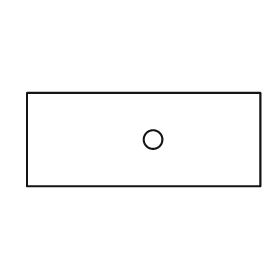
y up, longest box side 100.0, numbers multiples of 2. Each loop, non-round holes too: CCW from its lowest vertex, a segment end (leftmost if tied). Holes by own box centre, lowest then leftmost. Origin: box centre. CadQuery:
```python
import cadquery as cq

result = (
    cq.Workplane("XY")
    .moveTo(-50.0, -20.0)
    .lineTo(50.0, -20.0)
    .lineTo(50.0, 20.0)
    .lineTo(-50.0, 20.0)
    .close()
    .moveTo(4.0, 0.0)
    .circle(4.0)
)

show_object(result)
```